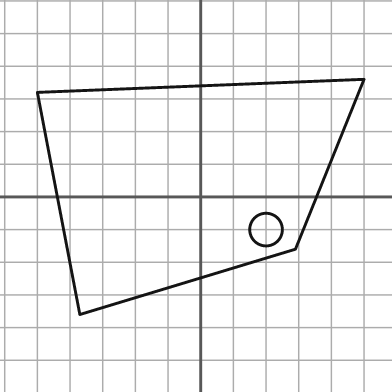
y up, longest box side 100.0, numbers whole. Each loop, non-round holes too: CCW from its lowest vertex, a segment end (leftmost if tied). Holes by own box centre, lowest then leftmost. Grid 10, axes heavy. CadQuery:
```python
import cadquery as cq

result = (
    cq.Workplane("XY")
    .moveTo(-37.0, -36.0)
    .lineTo(29.0, -16.0)
    .lineTo(50.0, 36.0)
    .lineTo(-50.0, 32.0)
    .close()
    .moveTo(20.0, -10.0)
    .circle(5.0)
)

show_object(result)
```